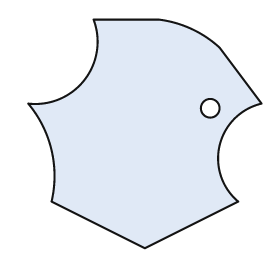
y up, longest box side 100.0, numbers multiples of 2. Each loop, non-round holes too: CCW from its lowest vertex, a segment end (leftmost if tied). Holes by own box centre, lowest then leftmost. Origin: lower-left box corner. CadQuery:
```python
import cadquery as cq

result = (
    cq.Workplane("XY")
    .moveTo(50.0, 0.0)
    .lineTo(90.0, 20.0)
    .threePointArc((82.0, 44.0), (100.0, 62.0))
    .lineTo(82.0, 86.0)
    .threePointArc((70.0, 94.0), (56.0, 98.0))
    .lineTo(28.0, 98.0)
    .threePointArc((24.0, 72.0), (0.0, 62.0))
    .threePointArc((10.0, 42.0), (10.0, 20.0))
    .close()
    .moveTo(78.0, 60.0)
    .circle(4.0)
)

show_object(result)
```